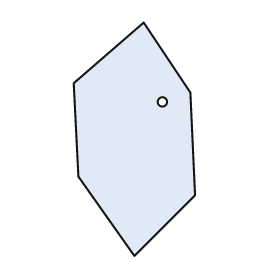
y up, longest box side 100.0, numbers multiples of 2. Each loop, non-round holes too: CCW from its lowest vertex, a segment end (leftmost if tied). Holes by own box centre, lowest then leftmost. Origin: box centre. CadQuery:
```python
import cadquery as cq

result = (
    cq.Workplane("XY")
    .moveTo(0.0, -50.0)
    .lineTo(26.0, -24.0)
    .lineTo(24.0, 20.0)
    .lineTo(4.0, 50.0)
    .lineTo(-26.0, 24.0)
    .lineTo(-24.0, -16.0)
    .close()
    .moveTo(12.0, 16.0)
    .circle(2.0)
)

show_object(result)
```